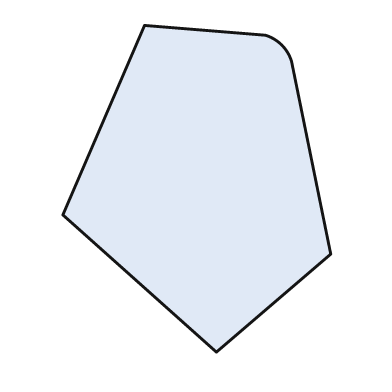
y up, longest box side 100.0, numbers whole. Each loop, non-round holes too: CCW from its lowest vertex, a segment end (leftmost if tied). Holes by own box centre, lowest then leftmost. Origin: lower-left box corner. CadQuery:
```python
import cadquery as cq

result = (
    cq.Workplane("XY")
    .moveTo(47.0, 0.0)
    .lineTo(82.0, 30.0)
    .lineTo(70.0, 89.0)
    .threePointArc((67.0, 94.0), (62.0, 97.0))
    .lineTo(25.0, 100.0)
    .lineTo(0.0, 42.0)
    .close()
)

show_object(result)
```